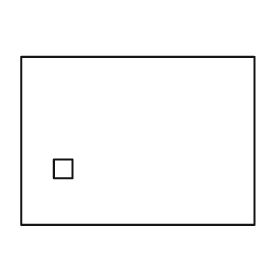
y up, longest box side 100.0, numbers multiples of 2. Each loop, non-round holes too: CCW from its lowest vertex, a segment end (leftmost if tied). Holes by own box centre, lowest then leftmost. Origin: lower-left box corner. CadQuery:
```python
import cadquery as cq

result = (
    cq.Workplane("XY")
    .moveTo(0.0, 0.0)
    .lineTo(100.0, 0.0)
    .lineTo(100.0, 72.0)
    .lineTo(0.0, 72.0)
    .close()
    .moveTo(14.0, 20.0)
    .lineTo(22.0, 20.0)
    .lineTo(22.0, 28.0)
    .lineTo(14.0, 28.0)
    .close()
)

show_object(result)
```